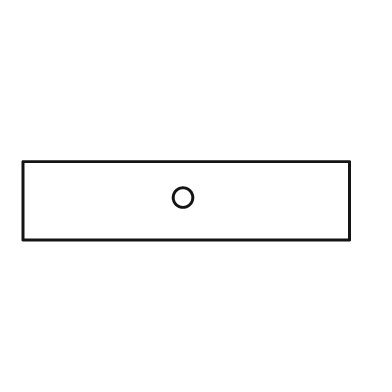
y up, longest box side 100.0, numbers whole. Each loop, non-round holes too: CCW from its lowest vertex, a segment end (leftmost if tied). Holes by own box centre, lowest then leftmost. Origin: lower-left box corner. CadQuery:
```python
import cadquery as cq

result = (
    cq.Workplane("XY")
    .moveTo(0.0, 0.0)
    .lineTo(100.0, 0.0)
    .lineTo(100.0, 24.0)
    .lineTo(0.0, 24.0)
    .close()
    .moveTo(49.0, 13.0)
    .circle(3.0)
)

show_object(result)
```